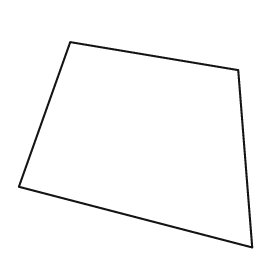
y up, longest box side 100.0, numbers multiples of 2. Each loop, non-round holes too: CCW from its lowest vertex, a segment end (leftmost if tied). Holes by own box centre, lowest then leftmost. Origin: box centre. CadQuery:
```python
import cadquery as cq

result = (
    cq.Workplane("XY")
    .moveTo(50.0, -44.0)
    .lineTo(44.0, 32.0)
    .lineTo(-28.0, 44.0)
    .lineTo(-50.0, -18.0)
    .close()
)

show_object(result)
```